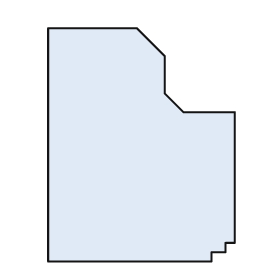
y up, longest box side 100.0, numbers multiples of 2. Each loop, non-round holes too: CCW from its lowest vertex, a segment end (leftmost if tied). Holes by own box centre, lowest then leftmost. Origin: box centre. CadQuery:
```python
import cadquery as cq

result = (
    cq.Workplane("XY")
    .moveTo(-40.0, -50.0)
    .lineTo(30.0, -50.0)
    .lineTo(30.0, -46.0)
    .lineTo(36.0, -46.0)
    .lineTo(36.0, -42.0)
    .lineTo(40.0, -42.0)
    .lineTo(40.0, 14.0)
    .lineTo(18.0, 14.0)
    .lineTo(10.0, 22.0)
    .lineTo(10.0, 38.0)
    .lineTo(-2.0, 50.0)
    .lineTo(-40.0, 50.0)
    .close()
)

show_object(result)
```